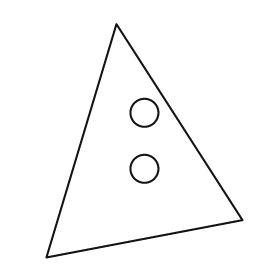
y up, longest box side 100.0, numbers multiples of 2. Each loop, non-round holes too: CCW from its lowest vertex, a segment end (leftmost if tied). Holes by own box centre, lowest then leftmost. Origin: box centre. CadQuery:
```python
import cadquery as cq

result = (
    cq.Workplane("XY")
    .moveTo(-42.0, -50.0)
    .lineTo(42.0, -34.0)
    .lineTo(-12.0, 50.0)
    .close()
    .moveTo(0.0, -12.0)
    .circle(6.0)
    .moveTo(0.0, 12.0)
    .circle(6.0)
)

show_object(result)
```